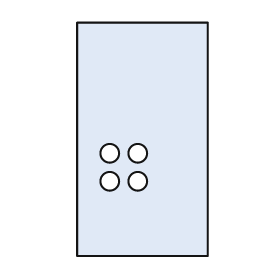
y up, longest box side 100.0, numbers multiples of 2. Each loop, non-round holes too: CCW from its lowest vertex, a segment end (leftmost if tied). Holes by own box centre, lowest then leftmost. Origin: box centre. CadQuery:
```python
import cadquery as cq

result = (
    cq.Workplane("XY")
    .moveTo(-28.0, -50.0)
    .lineTo(28.0, -50.0)
    .lineTo(28.0, 50.0)
    .lineTo(-28.0, 50.0)
    .close()
    .moveTo(-14.0, -18.0)
    .circle(4.0)
    .moveTo(-2.0, -18.0)
    .circle(4.0)
    .moveTo(-14.0, -6.0)
    .circle(4.0)
    .moveTo(-2.0, -6.0)
    .circle(4.0)
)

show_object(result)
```